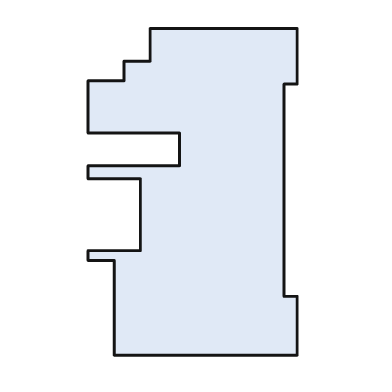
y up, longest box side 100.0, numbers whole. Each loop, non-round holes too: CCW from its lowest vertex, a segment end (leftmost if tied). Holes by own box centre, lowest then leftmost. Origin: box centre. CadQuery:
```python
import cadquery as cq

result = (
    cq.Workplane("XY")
    .moveTo(-24.0, -50.0)
    .lineTo(32.0, -50.0)
    .lineTo(32.0, -32.0)
    .lineTo(28.0, -32.0)
    .lineTo(28.0, 33.0)
    .lineTo(32.0, 33.0)
    .lineTo(32.0, 50.0)
    .lineTo(-13.0, 50.0)
    .lineTo(-13.0, 40.0)
    .lineTo(-21.0, 40.0)
    .lineTo(-21.0, 34.0)
    .lineTo(-32.0, 34.0)
    .lineTo(-32.0, 18.0)
    .lineTo(-4.0, 18.0)
    .lineTo(-4.0, 8.0)
    .lineTo(-32.0, 8.0)
    .lineTo(-32.0, 4.0)
    .lineTo(-16.0, 4.0)
    .lineTo(-16.0, -18.0)
    .lineTo(-32.0, -18.0)
    .lineTo(-32.0, -21.0)
    .lineTo(-24.0, -21.0)
    .close()
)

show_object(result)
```